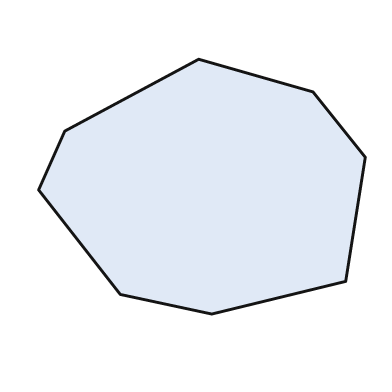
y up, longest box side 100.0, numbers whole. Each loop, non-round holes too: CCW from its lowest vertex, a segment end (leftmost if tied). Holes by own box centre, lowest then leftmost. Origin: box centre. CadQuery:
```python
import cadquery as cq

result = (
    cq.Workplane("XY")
    .moveTo(3.0, -39.0)
    .lineTo(44.0, -29.0)
    .lineTo(50.0, 9.0)
    .lineTo(34.0, 29.0)
    .lineTo(-1.0, 39.0)
    .lineTo(-42.0, 17.0)
    .lineTo(-50.0, -1.0)
    .lineTo(-25.0, -33.0)
    .close()
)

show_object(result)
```